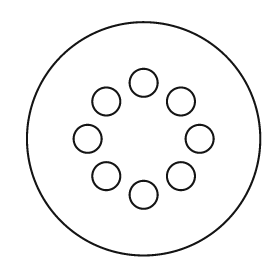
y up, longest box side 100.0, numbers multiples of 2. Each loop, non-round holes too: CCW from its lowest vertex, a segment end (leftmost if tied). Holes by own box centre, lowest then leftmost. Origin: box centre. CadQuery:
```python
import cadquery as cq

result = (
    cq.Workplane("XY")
    .moveTo(0.0, 0.0)
    .circle(50.0)
    .moveTo(0.0, -24.0)
    .circle(6.0)
    .moveTo(-16.0, -16.0)
    .circle(6.0)
    .moveTo(16.0, -16.0)
    .circle(6.0)
    .moveTo(-24.0, 0.0)
    .circle(6.0)
    .moveTo(24.0, 0.0)
    .circle(6.0)
    .moveTo(-16.0, 16.0)
    .circle(6.0)
    .moveTo(16.0, 16.0)
    .circle(6.0)
    .moveTo(0.0, 24.0)
    .circle(6.0)
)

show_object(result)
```